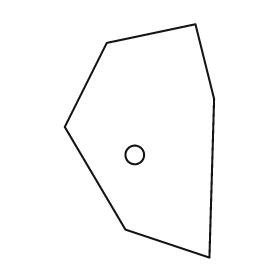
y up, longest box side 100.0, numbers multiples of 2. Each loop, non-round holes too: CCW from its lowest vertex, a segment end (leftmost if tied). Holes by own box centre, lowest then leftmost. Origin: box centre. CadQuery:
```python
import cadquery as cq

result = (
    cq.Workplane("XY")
    .moveTo(30.0, -50.0)
    .lineTo(32.0, 18.0)
    .lineTo(24.0, 50.0)
    .lineTo(-14.0, 42.0)
    .lineTo(-32.0, 6.0)
    .lineTo(-6.0, -38.0)
    .close()
    .moveTo(-2.0, -6.0)
    .circle(4.0)
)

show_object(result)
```